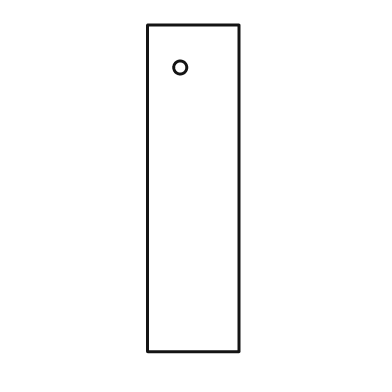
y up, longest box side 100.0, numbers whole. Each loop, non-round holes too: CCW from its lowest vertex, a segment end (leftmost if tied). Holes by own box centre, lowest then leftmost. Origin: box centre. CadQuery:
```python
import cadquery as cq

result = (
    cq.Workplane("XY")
    .moveTo(-14.0, -50.0)
    .lineTo(14.0, -50.0)
    .lineTo(14.0, 50.0)
    .lineTo(-14.0, 50.0)
    .close()
    .moveTo(-4.0, 37.0)
    .circle(2.0)
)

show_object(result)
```